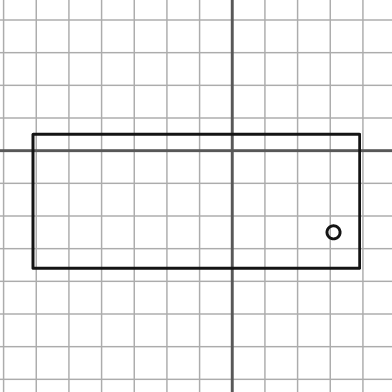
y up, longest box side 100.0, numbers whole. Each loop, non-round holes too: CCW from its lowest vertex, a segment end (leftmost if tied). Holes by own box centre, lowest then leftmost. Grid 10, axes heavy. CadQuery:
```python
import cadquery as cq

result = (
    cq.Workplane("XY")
    .moveTo(-61.0, -36.0)
    .lineTo(39.0, -36.0)
    .lineTo(39.0, 5.0)
    .lineTo(-61.0, 5.0)
    .close()
    .moveTo(31.0, -25.0)
    .circle(2.0)
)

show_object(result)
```